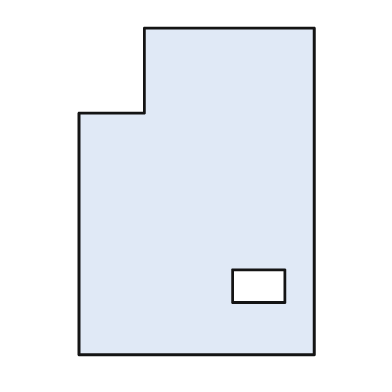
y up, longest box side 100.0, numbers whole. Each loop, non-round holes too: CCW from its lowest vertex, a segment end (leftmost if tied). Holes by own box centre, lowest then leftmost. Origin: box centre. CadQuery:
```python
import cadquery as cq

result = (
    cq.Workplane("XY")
    .moveTo(-36.0, -50.0)
    .lineTo(36.0, -50.0)
    .lineTo(36.0, 50.0)
    .lineTo(-16.0, 50.0)
    .lineTo(-16.0, 24.0)
    .lineTo(-36.0, 24.0)
    .close()
    .moveTo(11.0, -34.0)
    .lineTo(27.0, -34.0)
    .lineTo(27.0, -24.0)
    .lineTo(11.0, -24.0)
    .close()
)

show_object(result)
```